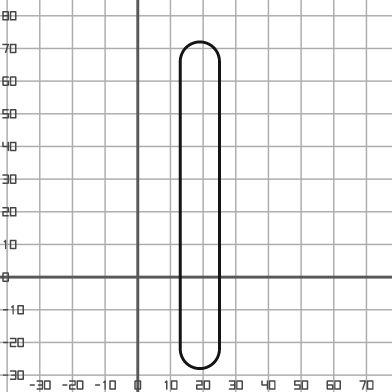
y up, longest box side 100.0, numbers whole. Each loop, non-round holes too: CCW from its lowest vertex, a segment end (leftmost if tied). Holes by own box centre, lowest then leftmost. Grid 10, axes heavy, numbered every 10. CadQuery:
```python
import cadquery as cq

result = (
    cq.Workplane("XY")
    .moveTo(13.0, -22.0)
    .threePointArc((19.0, -28.0), (25.0, -22.0))
    .lineTo(25.0, 66.0)
    .threePointArc((19.0, 72.0), (13.0, 66.0))
    .close()
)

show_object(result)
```